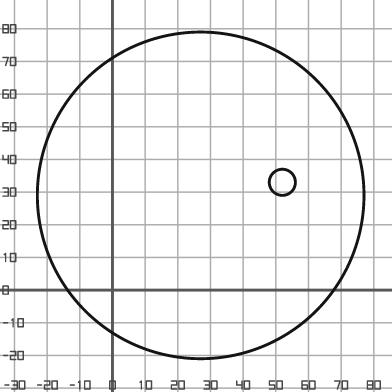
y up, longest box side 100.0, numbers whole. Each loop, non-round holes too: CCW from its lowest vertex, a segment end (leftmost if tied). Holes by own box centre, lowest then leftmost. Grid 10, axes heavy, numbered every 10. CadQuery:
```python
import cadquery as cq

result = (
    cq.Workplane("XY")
    .moveTo(27.0, 29.0)
    .circle(50.0)
    .moveTo(52.0, 33.0)
    .circle(4.0)
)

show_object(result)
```